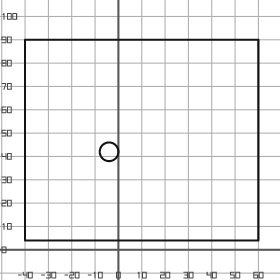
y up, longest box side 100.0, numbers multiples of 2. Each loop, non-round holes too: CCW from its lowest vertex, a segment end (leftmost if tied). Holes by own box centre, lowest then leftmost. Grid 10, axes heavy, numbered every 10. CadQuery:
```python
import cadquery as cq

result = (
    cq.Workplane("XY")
    .moveTo(-40.0, 4.0)
    .lineTo(60.0, 4.0)
    .lineTo(60.0, 90.0)
    .lineTo(-40.0, 90.0)
    .close()
    .moveTo(-4.0, 42.0)
    .circle(4.0)
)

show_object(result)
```